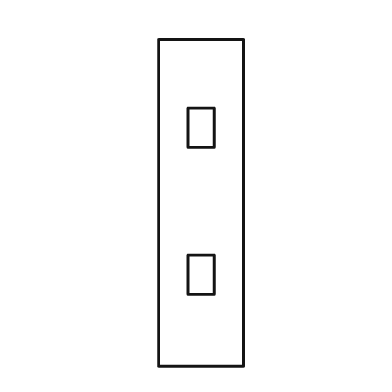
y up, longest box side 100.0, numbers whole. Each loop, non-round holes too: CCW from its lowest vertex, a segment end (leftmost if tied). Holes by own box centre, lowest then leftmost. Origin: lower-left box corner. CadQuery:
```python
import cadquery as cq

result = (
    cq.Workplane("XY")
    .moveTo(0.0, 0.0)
    .lineTo(26.0, 0.0)
    .lineTo(26.0, 100.0)
    .lineTo(0.0, 100.0)
    .close()
    .moveTo(9.0, 22.0)
    .lineTo(17.0, 22.0)
    .lineTo(17.0, 34.0)
    .lineTo(9.0, 34.0)
    .close()
    .moveTo(9.0, 67.0)
    .lineTo(17.0, 67.0)
    .lineTo(17.0, 79.0)
    .lineTo(9.0, 79.0)
    .close()
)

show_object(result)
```